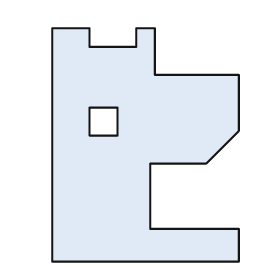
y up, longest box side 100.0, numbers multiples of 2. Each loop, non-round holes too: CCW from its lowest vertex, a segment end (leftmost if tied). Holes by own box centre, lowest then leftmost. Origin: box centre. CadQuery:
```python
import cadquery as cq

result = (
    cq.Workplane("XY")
    .moveTo(-40.0, -50.0)
    .lineTo(40.0, -50.0)
    .lineTo(40.0, -36.0)
    .lineTo(2.0, -36.0)
    .lineTo(2.0, -8.0)
    .lineTo(26.0, -8.0)
    .lineTo(40.0, 6.0)
    .lineTo(40.0, 30.0)
    .lineTo(4.0, 30.0)
    .lineTo(4.0, 50.0)
    .lineTo(-4.0, 50.0)
    .lineTo(-4.0, 42.0)
    .lineTo(-24.0, 42.0)
    .lineTo(-24.0, 50.0)
    .lineTo(-40.0, 50.0)
    .close()
    .moveTo(-24.0, 4.0)
    .lineTo(-12.0, 4.0)
    .lineTo(-12.0, 16.0)
    .lineTo(-24.0, 16.0)
    .close()
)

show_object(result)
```